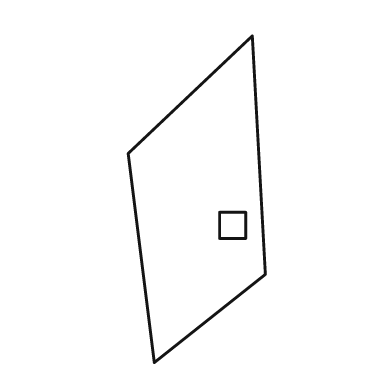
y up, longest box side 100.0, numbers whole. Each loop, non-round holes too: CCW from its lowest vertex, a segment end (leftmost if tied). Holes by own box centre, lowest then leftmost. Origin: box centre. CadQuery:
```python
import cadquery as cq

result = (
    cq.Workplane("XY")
    .moveTo(-13.0, -50.0)
    .lineTo(21.0, -23.0)
    .lineTo(17.0, 50.0)
    .lineTo(-21.0, 14.0)
    .close()
    .moveTo(7.0, -12.0)
    .lineTo(15.0, -12.0)
    .lineTo(15.0, -4.0)
    .lineTo(7.0, -4.0)
    .close()
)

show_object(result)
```